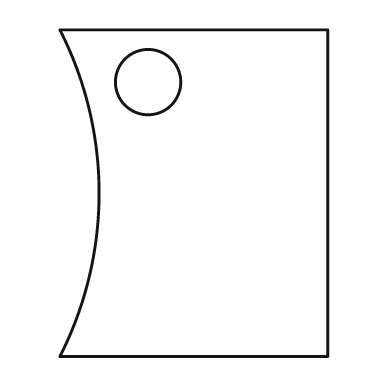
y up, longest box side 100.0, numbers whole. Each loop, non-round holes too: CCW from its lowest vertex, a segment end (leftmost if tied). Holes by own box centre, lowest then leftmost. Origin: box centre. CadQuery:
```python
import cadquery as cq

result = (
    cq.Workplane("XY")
    .moveTo(-41.0, -50.0)
    .lineTo(41.0, -50.0)
    .lineTo(41.0, 50.0)
    .lineTo(-41.0, 50.0)
    .threePointArc((-29.0, 0.0), (-41.0, -50.0))
    .close()
    .moveTo(-14.0, 34.0)
    .circle(10.0)
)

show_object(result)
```